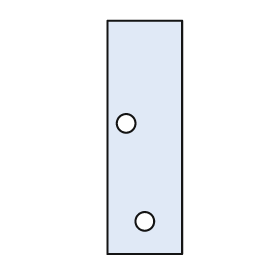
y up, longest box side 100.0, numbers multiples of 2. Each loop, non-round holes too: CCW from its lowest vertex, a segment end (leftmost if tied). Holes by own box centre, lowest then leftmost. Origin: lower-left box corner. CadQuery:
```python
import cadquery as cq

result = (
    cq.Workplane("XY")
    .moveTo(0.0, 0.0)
    .lineTo(32.0, 0.0)
    .lineTo(32.0, 100.0)
    .lineTo(0.0, 100.0)
    .close()
    .moveTo(16.0, 14.0)
    .circle(4.0)
    .moveTo(8.0, 56.0)
    .circle(4.0)
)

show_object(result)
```